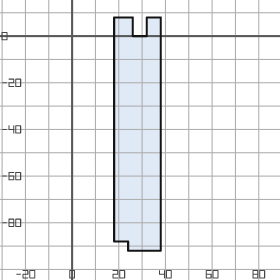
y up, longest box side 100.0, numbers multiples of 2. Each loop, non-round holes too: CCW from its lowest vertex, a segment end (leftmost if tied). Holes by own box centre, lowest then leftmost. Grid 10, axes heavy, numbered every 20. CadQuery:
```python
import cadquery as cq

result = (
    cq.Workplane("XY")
    .moveTo(24.0, -92.0)
    .lineTo(38.0, -92.0)
    .lineTo(38.0, 8.0)
    .lineTo(32.0, 8.0)
    .lineTo(32.0, 0.0)
    .lineTo(26.0, 0.0)
    .lineTo(26.0, 8.0)
    .lineTo(18.0, 8.0)
    .lineTo(18.0, -88.0)
    .lineTo(24.0, -88.0)
    .close()
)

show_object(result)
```